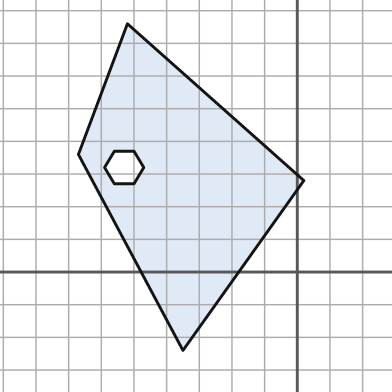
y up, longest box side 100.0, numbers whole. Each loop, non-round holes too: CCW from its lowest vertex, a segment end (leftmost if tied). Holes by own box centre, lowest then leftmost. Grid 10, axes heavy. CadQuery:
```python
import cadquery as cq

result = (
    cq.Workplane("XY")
    .moveTo(-35.0, -24.0)
    .lineTo(2.0, 28.0)
    .lineTo(-52.0, 76.0)
    .lineTo(-67.0, 36.0)
    .close()
    .moveTo(-56.0, 27.0)
    .lineTo(-50.0, 27.0)
    .lineTo(-47.0, 32.0)
    .lineTo(-50.0, 37.0)
    .lineTo(-56.0, 37.0)
    .lineTo(-59.0, 32.0)
    .close()
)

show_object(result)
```